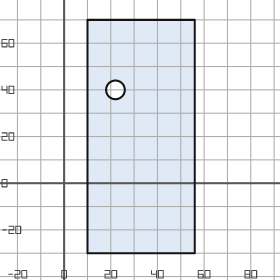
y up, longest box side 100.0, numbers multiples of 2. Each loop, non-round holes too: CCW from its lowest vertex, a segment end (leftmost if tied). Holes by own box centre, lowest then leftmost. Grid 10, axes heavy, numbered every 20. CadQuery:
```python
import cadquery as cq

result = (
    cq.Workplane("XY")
    .moveTo(10.0, -30.0)
    .lineTo(56.0, -30.0)
    .lineTo(56.0, 70.0)
    .lineTo(10.0, 70.0)
    .close()
    .moveTo(22.0, 40.0)
    .circle(4.0)
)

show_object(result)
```